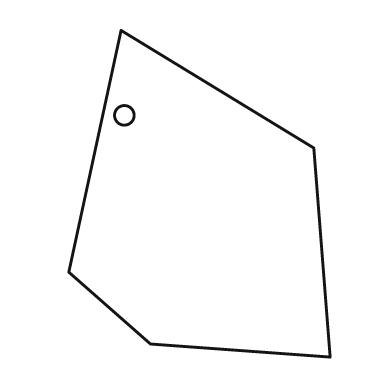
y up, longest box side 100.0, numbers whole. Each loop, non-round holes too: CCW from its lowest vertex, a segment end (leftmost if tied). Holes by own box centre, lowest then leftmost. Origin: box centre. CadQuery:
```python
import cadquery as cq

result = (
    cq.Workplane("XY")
    .moveTo(40.0, -50.0)
    .lineTo(35.0, 14.0)
    .lineTo(-24.0, 50.0)
    .lineTo(-40.0, -24.0)
    .lineTo(-15.0, -46.0)
    .close()
    .moveTo(-23.0, 24.0)
    .circle(3.0)
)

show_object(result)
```